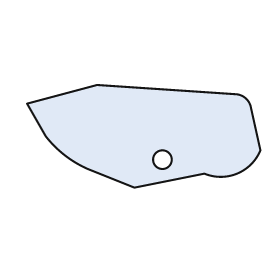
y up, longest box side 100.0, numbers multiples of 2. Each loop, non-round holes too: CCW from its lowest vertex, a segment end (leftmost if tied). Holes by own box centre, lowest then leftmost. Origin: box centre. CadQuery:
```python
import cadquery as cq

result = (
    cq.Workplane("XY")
    .moveTo(-4.0, -22.0)
    .lineTo(26.0, -16.0)
    .threePointArc((40.0, -16.0), (50.0, -6.0))
    .lineTo(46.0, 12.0)
    .threePointArc((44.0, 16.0), (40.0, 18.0))
    .lineTo(-20.0, 22.0)
    .lineTo(-50.0, 14.0)
    .lineTo(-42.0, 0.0)
    .threePointArc((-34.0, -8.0), (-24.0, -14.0))
    .close()
    .moveTo(8.0, -10.0)
    .circle(4.0)
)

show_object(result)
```